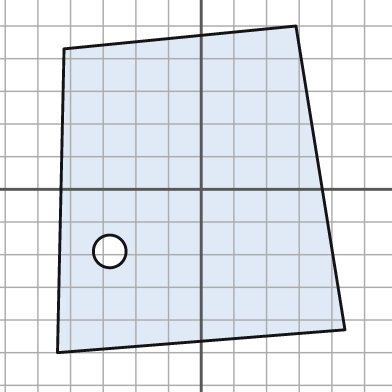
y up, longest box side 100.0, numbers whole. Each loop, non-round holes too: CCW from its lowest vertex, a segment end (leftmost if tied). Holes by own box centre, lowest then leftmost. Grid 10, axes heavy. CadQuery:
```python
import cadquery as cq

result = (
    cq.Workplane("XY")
    .moveTo(-44.0, -50.0)
    .lineTo(44.0, -43.0)
    .lineTo(29.0, 50.0)
    .lineTo(-42.0, 43.0)
    .close()
    .moveTo(-28.0, -19.0)
    .circle(5.0)
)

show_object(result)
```